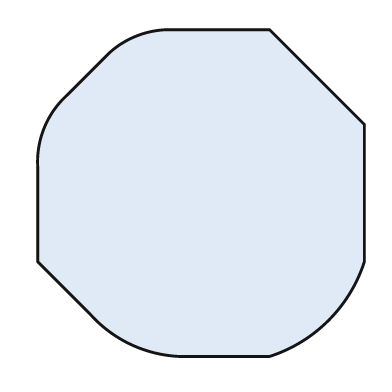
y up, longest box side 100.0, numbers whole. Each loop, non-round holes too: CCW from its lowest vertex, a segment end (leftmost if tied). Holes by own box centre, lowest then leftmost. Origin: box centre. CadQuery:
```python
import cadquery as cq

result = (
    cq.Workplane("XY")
    .moveTo(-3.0, -50.0)
    .lineTo(21.0, -50.0)
    .threePointArc((39.0, -39.0), (50.0, -21.0))
    .lineTo(50.0, 21.0)
    .lineTo(21.0, 50.0)
    .lineTo(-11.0, 50.0)
    .threePointArc((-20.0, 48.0), (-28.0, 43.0))
    .lineTo(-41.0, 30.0)
    .threePointArc((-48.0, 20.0), (-50.0, 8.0))
    .lineTo(-50.0, -21.0)
    .lineTo(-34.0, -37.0)
    .threePointArc((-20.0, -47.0), (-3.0, -50.0))
    .close()
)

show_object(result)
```